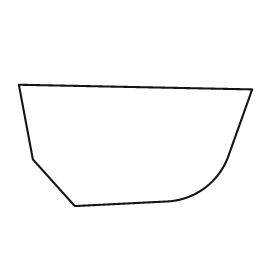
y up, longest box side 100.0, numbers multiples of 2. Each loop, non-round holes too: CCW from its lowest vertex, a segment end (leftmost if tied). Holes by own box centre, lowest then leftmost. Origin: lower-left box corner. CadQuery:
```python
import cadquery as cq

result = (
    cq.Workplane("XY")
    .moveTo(24.0, 0.0)
    .lineTo(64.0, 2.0)
    .threePointArc((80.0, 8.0), (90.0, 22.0))
    .lineTo(100.0, 50.0)
    .lineTo(0.0, 52.0)
    .lineTo(6.0, 20.0)
    .close()
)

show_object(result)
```